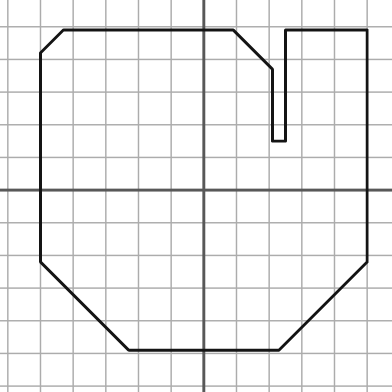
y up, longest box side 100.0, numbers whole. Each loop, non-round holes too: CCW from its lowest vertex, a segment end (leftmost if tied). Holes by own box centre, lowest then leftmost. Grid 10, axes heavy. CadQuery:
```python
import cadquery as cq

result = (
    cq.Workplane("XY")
    .moveTo(-23.0, -49.0)
    .lineTo(23.0, -49.0)
    .lineTo(50.0, -22.0)
    .lineTo(50.0, 49.0)
    .lineTo(25.0, 49.0)
    .lineTo(25.0, 15.0)
    .lineTo(21.0, 15.0)
    .lineTo(21.0, 37.0)
    .lineTo(9.0, 49.0)
    .lineTo(-43.0, 49.0)
    .lineTo(-50.0, 42.0)
    .lineTo(-50.0, -22.0)
    .close()
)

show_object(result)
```